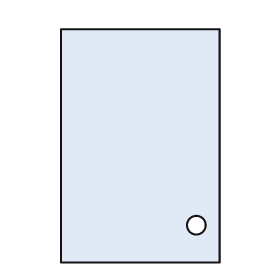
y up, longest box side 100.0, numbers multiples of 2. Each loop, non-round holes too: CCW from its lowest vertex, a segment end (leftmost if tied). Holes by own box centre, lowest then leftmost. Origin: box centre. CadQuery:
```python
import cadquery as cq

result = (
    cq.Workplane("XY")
    .moveTo(-34.0, -50.0)
    .lineTo(34.0, -50.0)
    .lineTo(34.0, 50.0)
    .lineTo(-34.0, 50.0)
    .close()
    .moveTo(24.0, -34.0)
    .circle(4.0)
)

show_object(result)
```